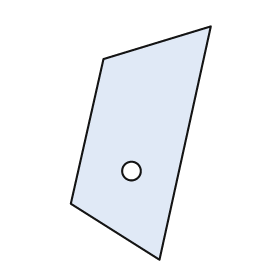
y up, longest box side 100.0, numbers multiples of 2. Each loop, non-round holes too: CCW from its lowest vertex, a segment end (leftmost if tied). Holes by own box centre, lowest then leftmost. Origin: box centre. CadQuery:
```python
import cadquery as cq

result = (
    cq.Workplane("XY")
    .moveTo(8.0, -50.0)
    .lineTo(30.0, 50.0)
    .lineTo(-16.0, 36.0)
    .lineTo(-30.0, -26.0)
    .close()
    .moveTo(-4.0, -12.0)
    .circle(4.0)
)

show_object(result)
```